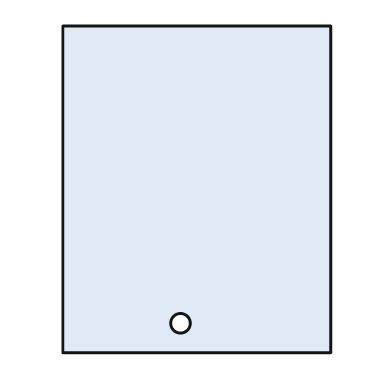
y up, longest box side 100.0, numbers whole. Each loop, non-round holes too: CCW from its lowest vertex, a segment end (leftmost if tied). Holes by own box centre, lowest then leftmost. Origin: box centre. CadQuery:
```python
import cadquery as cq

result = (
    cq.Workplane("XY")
    .moveTo(-41.0, -50.0)
    .lineTo(41.0, -50.0)
    .lineTo(41.0, 50.0)
    .lineTo(-41.0, 50.0)
    .close()
    .moveTo(-5.0, -41.0)
    .circle(3.0)
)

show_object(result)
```